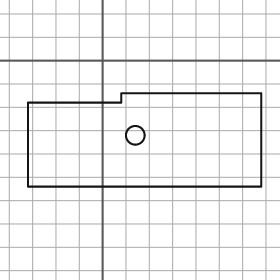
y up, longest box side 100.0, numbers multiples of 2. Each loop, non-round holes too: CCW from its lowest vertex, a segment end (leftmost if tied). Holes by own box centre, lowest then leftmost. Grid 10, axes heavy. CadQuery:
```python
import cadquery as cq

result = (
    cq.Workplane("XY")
    .moveTo(-32.0, -54.0)
    .lineTo(68.0, -54.0)
    .lineTo(68.0, -14.0)
    .lineTo(8.0, -14.0)
    .lineTo(8.0, -18.0)
    .lineTo(-32.0, -18.0)
    .close()
    .moveTo(14.0, -32.0)
    .circle(4.0)
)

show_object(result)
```